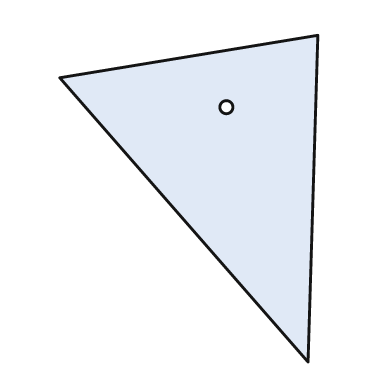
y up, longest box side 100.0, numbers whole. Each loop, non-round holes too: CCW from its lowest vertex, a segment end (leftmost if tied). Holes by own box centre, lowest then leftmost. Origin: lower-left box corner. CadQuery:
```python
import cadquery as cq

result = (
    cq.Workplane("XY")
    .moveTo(76.0, 0.0)
    .lineTo(79.0, 100.0)
    .lineTo(0.0, 87.0)
    .close()
    .moveTo(51.0, 78.0)
    .circle(2.0)
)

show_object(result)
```